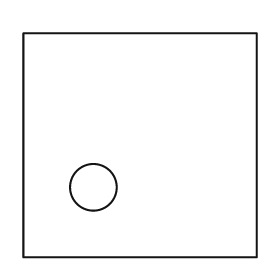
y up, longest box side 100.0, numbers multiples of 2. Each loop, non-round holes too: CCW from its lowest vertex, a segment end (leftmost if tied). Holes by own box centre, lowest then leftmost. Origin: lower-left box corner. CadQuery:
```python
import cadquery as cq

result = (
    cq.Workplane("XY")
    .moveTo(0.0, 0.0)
    .lineTo(100.0, 0.0)
    .lineTo(100.0, 96.0)
    .lineTo(0.0, 96.0)
    .close()
    .moveTo(30.0, 30.0)
    .circle(10.0)
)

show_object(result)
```